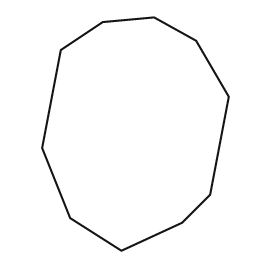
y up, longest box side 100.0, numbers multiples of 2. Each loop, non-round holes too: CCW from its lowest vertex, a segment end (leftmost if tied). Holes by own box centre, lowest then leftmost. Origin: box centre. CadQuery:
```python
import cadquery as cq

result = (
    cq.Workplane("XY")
    .moveTo(-6.0, -50.0)
    .lineTo(20.0, -38.0)
    .lineTo(32.0, -26.0)
    .lineTo(40.0, 16.0)
    .lineTo(26.0, 40.0)
    .lineTo(8.0, 50.0)
    .lineTo(-14.0, 48.0)
    .lineTo(-32.0, 36.0)
    .lineTo(-40.0, -6.0)
    .lineTo(-28.0, -36.0)
    .close()
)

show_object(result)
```